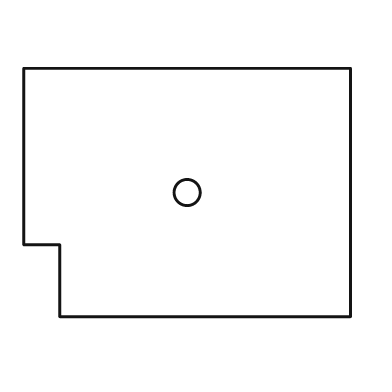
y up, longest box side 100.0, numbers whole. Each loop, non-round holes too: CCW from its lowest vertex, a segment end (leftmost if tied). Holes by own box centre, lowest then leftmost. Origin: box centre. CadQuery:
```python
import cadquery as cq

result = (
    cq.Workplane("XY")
    .moveTo(-39.0, -38.0)
    .lineTo(50.0, -38.0)
    .lineTo(50.0, 38.0)
    .lineTo(-50.0, 38.0)
    .lineTo(-50.0, -16.0)
    .lineTo(-39.0, -16.0)
    .close()
    .moveTo(0.0, 0.0)
    .circle(4.0)
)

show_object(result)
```